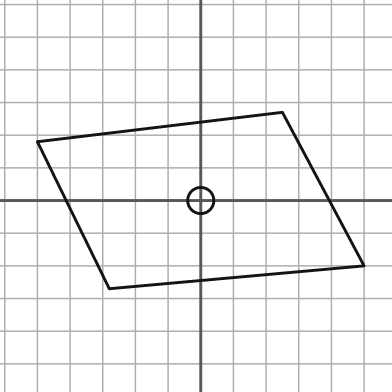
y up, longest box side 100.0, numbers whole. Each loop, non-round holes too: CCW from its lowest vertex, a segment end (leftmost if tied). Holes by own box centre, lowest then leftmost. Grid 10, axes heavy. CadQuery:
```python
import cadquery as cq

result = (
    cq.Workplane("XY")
    .moveTo(-28.0, -27.0)
    .lineTo(50.0, -20.0)
    .lineTo(25.0, 27.0)
    .lineTo(-50.0, 18.0)
    .close()
    .moveTo(0.0, 0.0)
    .circle(4.0)
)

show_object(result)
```